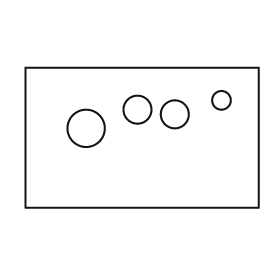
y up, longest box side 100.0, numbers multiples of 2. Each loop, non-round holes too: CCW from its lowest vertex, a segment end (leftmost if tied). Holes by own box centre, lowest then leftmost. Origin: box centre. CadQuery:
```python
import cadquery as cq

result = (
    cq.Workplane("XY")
    .moveTo(-50.0, -30.0)
    .lineTo(50.0, -30.0)
    .lineTo(50.0, 30.0)
    .lineTo(-50.0, 30.0)
    .close()
    .moveTo(-24.0, 4.0)
    .circle(8.0)
    .moveTo(14.0, 10.0)
    .circle(6.0)
    .moveTo(-2.0, 12.0)
    .circle(6.0)
    .moveTo(34.0, 16.0)
    .circle(4.0)
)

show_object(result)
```